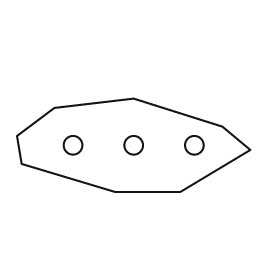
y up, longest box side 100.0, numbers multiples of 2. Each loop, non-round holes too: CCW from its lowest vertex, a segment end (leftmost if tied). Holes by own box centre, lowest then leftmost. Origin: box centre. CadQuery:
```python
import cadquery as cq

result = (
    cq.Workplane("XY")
    .moveTo(-8.0, -20.0)
    .lineTo(20.0, -20.0)
    .lineTo(50.0, -2.0)
    .lineTo(38.0, 8.0)
    .lineTo(0.0, 20.0)
    .lineTo(-34.0, 16.0)
    .lineTo(-50.0, 4.0)
    .lineTo(-48.0, -8.0)
    .close()
    .moveTo(-26.0, 0.0)
    .circle(4.0)
    .moveTo(0.0, 0.0)
    .circle(4.0)
    .moveTo(26.0, 0.0)
    .circle(4.0)
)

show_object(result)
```